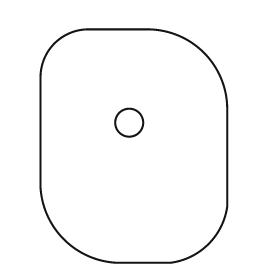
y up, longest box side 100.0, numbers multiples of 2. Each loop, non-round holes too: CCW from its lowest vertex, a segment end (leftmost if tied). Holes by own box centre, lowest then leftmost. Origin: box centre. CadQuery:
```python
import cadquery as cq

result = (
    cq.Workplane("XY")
    .moveTo(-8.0, -50.0)
    .lineTo(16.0, -50.0)
    .threePointArc((32.0, -42.0), (40.0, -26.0))
    .lineTo(40.0, 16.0)
    .threePointArc((30.0, 40.0), (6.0, 50.0))
    .lineTo(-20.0, 50.0)
    .threePointArc((-34.0, 44.0), (-40.0, 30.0))
    .lineTo(-40.0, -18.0)
    .threePointArc((-30.0, -40.0), (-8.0, -50.0))
    .close()
    .moveTo(-2.0, 10.0)
    .circle(6.0)
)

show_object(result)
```